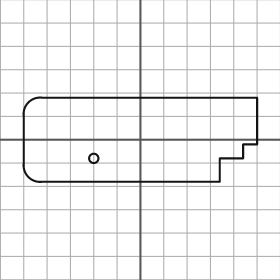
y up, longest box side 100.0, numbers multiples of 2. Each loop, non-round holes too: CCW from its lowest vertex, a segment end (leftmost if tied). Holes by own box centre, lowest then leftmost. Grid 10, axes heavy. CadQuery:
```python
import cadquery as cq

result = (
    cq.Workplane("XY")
    .moveTo(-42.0, -18.0)
    .lineTo(34.0, -18.0)
    .lineTo(34.0, -8.0)
    .lineTo(44.0, -8.0)
    .lineTo(44.0, -2.0)
    .lineTo(50.0, -2.0)
    .lineTo(50.0, 18.0)
    .lineTo(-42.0, 18.0)
    .threePointArc((-48.0, 16.0), (-50.0, 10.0))
    .lineTo(-50.0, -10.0)
    .threePointArc((-48.0, -16.0), (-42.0, -18.0))
    .close()
    .moveTo(-20.0, -8.0)
    .circle(2.0)
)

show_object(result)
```